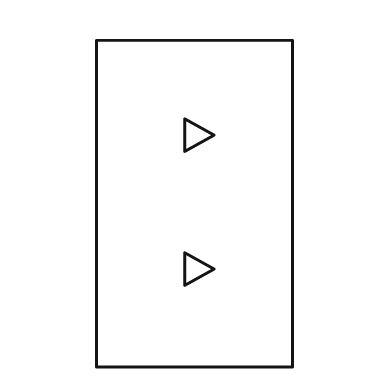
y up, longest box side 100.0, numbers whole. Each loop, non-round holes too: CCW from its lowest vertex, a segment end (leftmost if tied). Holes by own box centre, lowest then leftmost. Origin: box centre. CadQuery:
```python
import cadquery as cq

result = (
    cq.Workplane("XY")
    .moveTo(-30.0, -50.0)
    .lineTo(30.0, -50.0)
    .lineTo(30.0, 50.0)
    .lineTo(-30.0, 50.0)
    .close()
    .moveTo(-3.0, -25.0)
    .lineTo(6.0, -20.0)
    .lineTo(-3.0, -15.0)
    .close()
    .moveTo(-3.0, 16.0)
    .lineTo(6.0, 21.0)
    .lineTo(-3.0, 26.0)
    .close()
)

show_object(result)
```